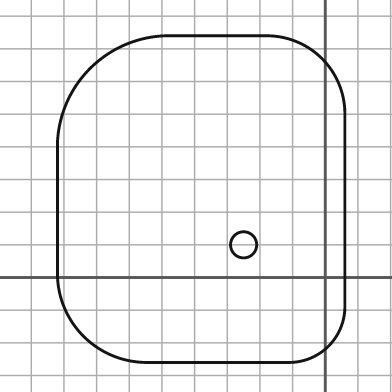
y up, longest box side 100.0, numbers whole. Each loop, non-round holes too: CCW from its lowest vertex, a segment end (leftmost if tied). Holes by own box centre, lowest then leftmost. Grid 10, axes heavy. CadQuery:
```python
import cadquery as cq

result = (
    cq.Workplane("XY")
    .moveTo(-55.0, -26.0)
    .lineTo(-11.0, -26.0)
    .threePointArc((1.0, -21.0), (6.0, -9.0))
    .lineTo(6.0, 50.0)
    .threePointArc((-1.0, 67.0), (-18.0, 74.0))
    .lineTo(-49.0, 74.0)
    .threePointArc((-72.0, 64.0), (-82.0, 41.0))
    .lineTo(-82.0, 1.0)
    .threePointArc((-74.0, -18.0), (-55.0, -26.0))
    .close()
    .moveTo(-25.0, 10.0)
    .circle(4.0)
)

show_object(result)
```